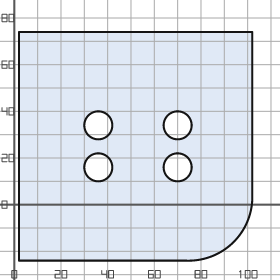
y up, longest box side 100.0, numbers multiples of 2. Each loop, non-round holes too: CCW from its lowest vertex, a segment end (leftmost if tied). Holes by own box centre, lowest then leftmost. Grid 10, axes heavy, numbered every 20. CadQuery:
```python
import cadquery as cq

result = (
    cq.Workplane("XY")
    .moveTo(2.0, -24.0)
    .lineTo(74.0, -24.0)
    .threePointArc((94.0, -16.0), (102.0, 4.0))
    .lineTo(102.0, 74.0)
    .lineTo(2.0, 74.0)
    .close()
    .moveTo(36.0, 16.0)
    .circle(6.0)
    .moveTo(70.0, 16.0)
    .circle(6.0)
    .moveTo(36.0, 34.0)
    .circle(6.0)
    .moveTo(70.0, 34.0)
    .circle(6.0)
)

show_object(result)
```